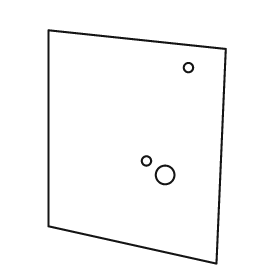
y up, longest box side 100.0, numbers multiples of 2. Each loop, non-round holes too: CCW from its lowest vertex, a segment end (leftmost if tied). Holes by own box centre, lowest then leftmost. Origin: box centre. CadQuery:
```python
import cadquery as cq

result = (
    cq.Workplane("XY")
    .moveTo(34.0, -50.0)
    .lineTo(38.0, 42.0)
    .lineTo(-38.0, 50.0)
    .lineTo(-38.0, -34.0)
    .close()
    .moveTo(12.0, -12.0)
    .circle(4.0)
    .moveTo(4.0, -6.0)
    .circle(2.0)
    .moveTo(22.0, 34.0)
    .circle(2.0)
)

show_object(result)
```